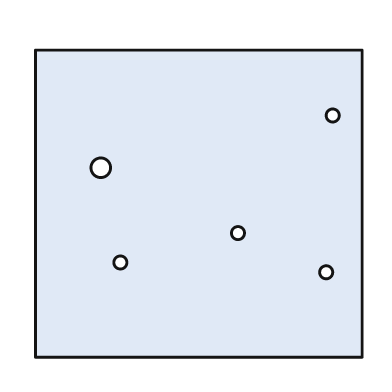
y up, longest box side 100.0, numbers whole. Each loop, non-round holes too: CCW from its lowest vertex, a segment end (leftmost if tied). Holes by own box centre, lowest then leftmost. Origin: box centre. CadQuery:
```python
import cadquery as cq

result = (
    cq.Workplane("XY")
    .moveTo(-50.0, -47.0)
    .lineTo(50.0, -47.0)
    .lineTo(50.0, 47.0)
    .lineTo(-50.0, 47.0)
    .close()
    .moveTo(39.0, -21.0)
    .circle(2.0)
    .moveTo(-24.0, -18.0)
    .circle(2.0)
    .moveTo(12.0, -9.0)
    .circle(2.0)
    .moveTo(-30.0, 11.0)
    .circle(3.0)
    .moveTo(41.0, 27.0)
    .circle(2.0)
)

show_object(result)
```